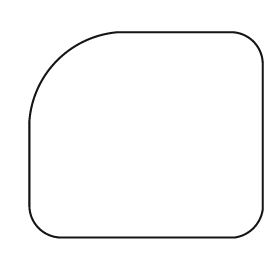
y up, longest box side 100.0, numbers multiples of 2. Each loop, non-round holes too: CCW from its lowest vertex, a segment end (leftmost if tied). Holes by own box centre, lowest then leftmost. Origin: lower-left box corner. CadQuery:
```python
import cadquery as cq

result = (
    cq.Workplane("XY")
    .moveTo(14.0, 0.0)
    .lineTo(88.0, 0.0)
    .threePointArc((96.0, 4.0), (100.0, 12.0))
    .lineTo(100.0, 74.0)
    .threePointArc((96.0, 84.0), (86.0, 88.0))
    .lineTo(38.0, 88.0)
    .threePointArc((12.0, 76.0), (0.0, 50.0))
    .lineTo(0.0, 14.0)
    .threePointArc((4.0, 4.0), (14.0, 0.0))
    .close()
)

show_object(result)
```